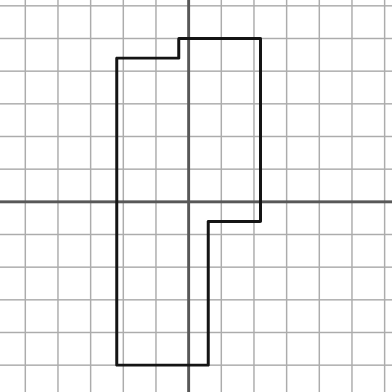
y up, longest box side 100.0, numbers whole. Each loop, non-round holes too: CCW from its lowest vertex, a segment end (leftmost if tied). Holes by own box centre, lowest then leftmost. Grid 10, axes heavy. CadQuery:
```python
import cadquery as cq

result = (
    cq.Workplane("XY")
    .moveTo(-22.0, -50.0)
    .lineTo(6.0, -50.0)
    .lineTo(6.0, -6.0)
    .lineTo(22.0, -6.0)
    .lineTo(22.0, 50.0)
    .lineTo(-3.0, 50.0)
    .lineTo(-3.0, 44.0)
    .lineTo(-22.0, 44.0)
    .close()
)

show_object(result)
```